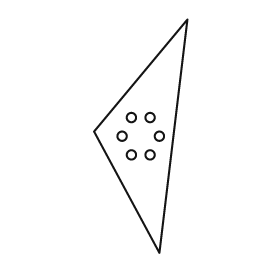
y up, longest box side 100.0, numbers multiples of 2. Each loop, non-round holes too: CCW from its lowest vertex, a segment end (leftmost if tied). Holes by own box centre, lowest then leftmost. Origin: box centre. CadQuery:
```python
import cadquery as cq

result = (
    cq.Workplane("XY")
    .moveTo(8.0, -50.0)
    .lineTo(20.0, 50.0)
    .lineTo(-20.0, 2.0)
    .close()
    .moveTo(-4.0, -8.0)
    .circle(2.0)
    .moveTo(4.0, -8.0)
    .circle(2.0)
    .moveTo(-8.0, 0.0)
    .circle(2.0)
    .moveTo(8.0, 0.0)
    .circle(2.0)
    .moveTo(-4.0, 8.0)
    .circle(2.0)
    .moveTo(4.0, 8.0)
    .circle(2.0)
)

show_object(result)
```